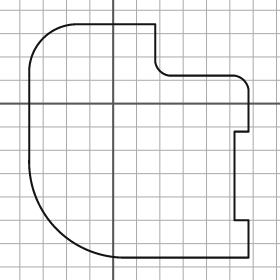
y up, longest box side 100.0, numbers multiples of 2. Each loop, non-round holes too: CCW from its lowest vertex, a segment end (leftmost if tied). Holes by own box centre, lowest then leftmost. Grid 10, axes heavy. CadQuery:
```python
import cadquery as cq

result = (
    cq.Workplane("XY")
    .moveTo(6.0, -66.0)
    .lineTo(58.0, -66.0)
    .lineTo(58.0, -50.0)
    .lineTo(52.0, -50.0)
    .lineTo(52.0, -12.0)
    .lineTo(58.0, -12.0)
    .lineTo(58.0, 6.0)
    .threePointArc((56.0, 10.0), (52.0, 12.0))
    .lineTo(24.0, 12.0)
    .threePointArc((20.0, 14.0), (18.0, 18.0))
    .lineTo(18.0, 34.0)
    .lineTo(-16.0, 34.0)
    .threePointArc((-30.0, 28.0), (-36.0, 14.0))
    .lineTo(-36.0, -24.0)
    .threePointArc((-24.0, -54.0), (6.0, -66.0))
    .close()
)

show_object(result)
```